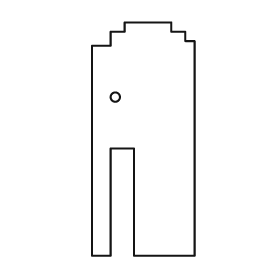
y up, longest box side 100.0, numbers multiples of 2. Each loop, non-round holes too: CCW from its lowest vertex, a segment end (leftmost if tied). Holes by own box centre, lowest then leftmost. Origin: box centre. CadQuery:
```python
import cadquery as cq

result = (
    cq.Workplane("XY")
    .moveTo(-22.0, -50.0)
    .lineTo(-14.0, -50.0)
    .lineTo(-14.0, -4.0)
    .lineTo(-4.0, -4.0)
    .lineTo(-4.0, -50.0)
    .lineTo(22.0, -50.0)
    .lineTo(22.0, 42.0)
    .lineTo(18.0, 42.0)
    .lineTo(18.0, 46.0)
    .lineTo(12.0, 46.0)
    .lineTo(12.0, 50.0)
    .lineTo(-8.0, 50.0)
    .lineTo(-8.0, 46.0)
    .lineTo(-14.0, 46.0)
    .lineTo(-14.0, 40.0)
    .lineTo(-22.0, 40.0)
    .close()
    .moveTo(-12.0, 18.0)
    .circle(2.0)
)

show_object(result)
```